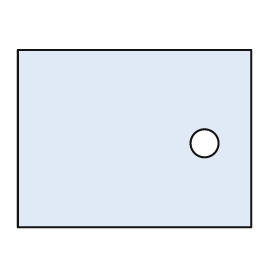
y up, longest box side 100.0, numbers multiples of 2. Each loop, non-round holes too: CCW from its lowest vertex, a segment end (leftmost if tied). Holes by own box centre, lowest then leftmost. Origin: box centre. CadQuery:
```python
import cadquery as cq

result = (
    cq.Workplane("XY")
    .moveTo(-50.0, -38.0)
    .lineTo(50.0, -38.0)
    .lineTo(50.0, 38.0)
    .lineTo(-50.0, 38.0)
    .close()
    .moveTo(30.0, -2.0)
    .circle(6.0)
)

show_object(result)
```